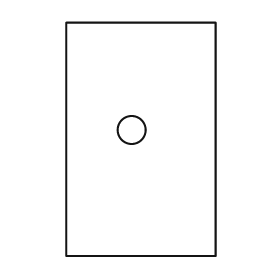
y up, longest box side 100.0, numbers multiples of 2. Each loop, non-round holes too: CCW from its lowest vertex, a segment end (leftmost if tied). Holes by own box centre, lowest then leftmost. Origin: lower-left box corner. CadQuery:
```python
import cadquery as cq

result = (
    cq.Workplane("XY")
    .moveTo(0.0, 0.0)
    .lineTo(64.0, 0.0)
    .lineTo(64.0, 100.0)
    .lineTo(0.0, 100.0)
    .close()
    .moveTo(28.0, 54.0)
    .circle(6.0)
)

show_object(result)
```